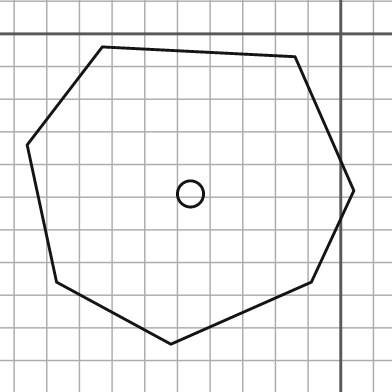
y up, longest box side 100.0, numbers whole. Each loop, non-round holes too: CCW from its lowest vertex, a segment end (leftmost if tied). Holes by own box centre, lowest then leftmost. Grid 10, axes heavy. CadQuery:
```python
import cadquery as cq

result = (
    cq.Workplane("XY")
    .moveTo(-52.0, -95.0)
    .lineTo(-9.0, -76.0)
    .lineTo(4.0, -48.0)
    .lineTo(-14.0, -7.0)
    .lineTo(-73.0, -4.0)
    .lineTo(-96.0, -34.0)
    .lineTo(-87.0, -76.0)
    .close()
    .moveTo(-46.0, -49.0)
    .circle(4.0)
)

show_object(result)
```